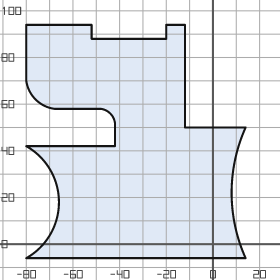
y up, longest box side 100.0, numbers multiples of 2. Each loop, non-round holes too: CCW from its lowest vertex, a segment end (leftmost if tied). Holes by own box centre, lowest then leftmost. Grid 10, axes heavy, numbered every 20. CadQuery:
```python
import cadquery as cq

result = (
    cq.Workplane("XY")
    .moveTo(-80.0, -6.0)
    .lineTo(14.0, -6.0)
    .threePointArc((8.0, 22.0), (14.0, 50.0))
    .lineTo(-12.0, 50.0)
    .lineTo(-12.0, 94.0)
    .lineTo(-20.0, 94.0)
    .lineTo(-20.0, 88.0)
    .lineTo(-52.0, 88.0)
    .lineTo(-52.0, 94.0)
    .lineTo(-80.0, 94.0)
    .lineTo(-80.0, 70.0)
    .threePointArc((-76.0, 62.0), (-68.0, 58.0))
    .lineTo(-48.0, 58.0)
    .threePointArc((-44.0, 56.0), (-42.0, 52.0))
    .lineTo(-42.0, 42.0)
    .lineTo(-80.0, 42.0)
    .threePointArc((-66.0, 18.0), (-80.0, -6.0))
    .close()
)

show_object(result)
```